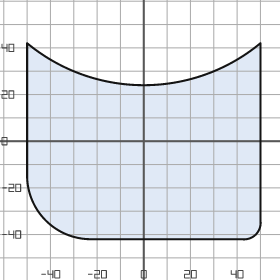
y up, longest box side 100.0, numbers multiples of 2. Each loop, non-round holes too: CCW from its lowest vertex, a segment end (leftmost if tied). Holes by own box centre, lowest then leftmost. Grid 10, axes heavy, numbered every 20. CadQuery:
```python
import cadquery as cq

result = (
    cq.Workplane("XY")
    .moveTo(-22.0, -42.0)
    .lineTo(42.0, -42.0)
    .threePointArc((48.0, -40.0), (50.0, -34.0))
    .lineTo(50.0, 42.0)
    .threePointArc((0.0, 24.0), (-50.0, 42.0))
    .lineTo(-50.0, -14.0)
    .threePointArc((-42.0, -34.0), (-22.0, -42.0))
    .close()
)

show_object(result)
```